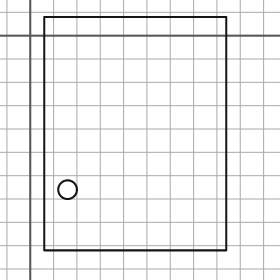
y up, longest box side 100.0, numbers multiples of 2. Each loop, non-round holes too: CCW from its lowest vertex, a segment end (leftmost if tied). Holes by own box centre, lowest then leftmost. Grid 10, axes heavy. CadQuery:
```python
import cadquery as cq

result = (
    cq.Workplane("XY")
    .moveTo(6.0, -92.0)
    .lineTo(84.0, -92.0)
    .lineTo(84.0, 8.0)
    .lineTo(6.0, 8.0)
    .close()
    .moveTo(16.0, -66.0)
    .circle(4.0)
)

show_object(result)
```